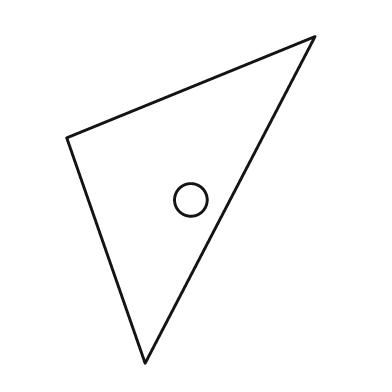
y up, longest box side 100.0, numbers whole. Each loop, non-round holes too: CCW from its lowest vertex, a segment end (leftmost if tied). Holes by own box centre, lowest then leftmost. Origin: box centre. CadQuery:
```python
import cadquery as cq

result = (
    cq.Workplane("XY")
    .moveTo(-14.0, -50.0)
    .lineTo(38.0, 50.0)
    .lineTo(-38.0, 19.0)
    .close()
    .moveTo(0.0, 0.0)
    .circle(5.0)
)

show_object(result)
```